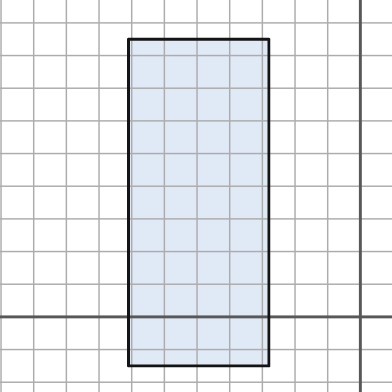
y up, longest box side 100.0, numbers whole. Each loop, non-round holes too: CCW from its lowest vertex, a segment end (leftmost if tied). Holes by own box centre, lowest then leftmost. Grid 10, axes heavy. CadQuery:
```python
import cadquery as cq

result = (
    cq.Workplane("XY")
    .moveTo(-71.0, -15.0)
    .lineTo(-28.0, -15.0)
    .lineTo(-28.0, 85.0)
    .lineTo(-71.0, 85.0)
    .close()
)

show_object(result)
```